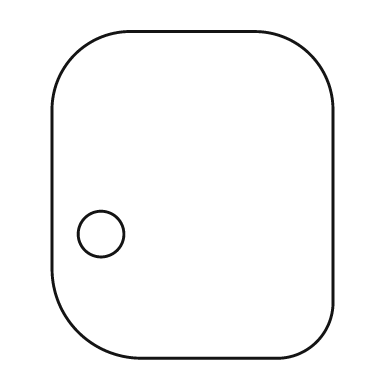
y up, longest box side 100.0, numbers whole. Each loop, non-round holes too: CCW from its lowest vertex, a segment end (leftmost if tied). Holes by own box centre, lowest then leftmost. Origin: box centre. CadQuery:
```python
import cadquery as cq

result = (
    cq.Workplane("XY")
    .moveTo(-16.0, -50.0)
    .lineTo(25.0, -50.0)
    .threePointArc((38.0, -45.0), (43.0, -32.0))
    .lineTo(43.0, 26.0)
    .threePointArc((36.0, 43.0), (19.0, 50.0))
    .lineTo(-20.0, 50.0)
    .threePointArc((-36.0, 43.0), (-43.0, 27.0))
    .lineTo(-43.0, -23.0)
    .threePointArc((-35.0, -42.0), (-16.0, -50.0))
    .close()
    .moveTo(-28.0, -12.0)
    .circle(7.0)
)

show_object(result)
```